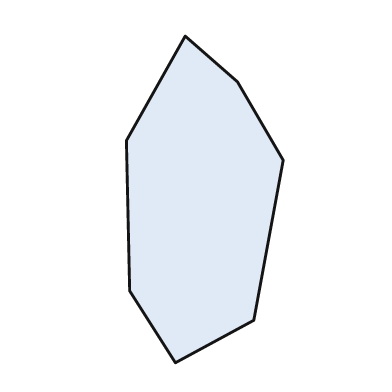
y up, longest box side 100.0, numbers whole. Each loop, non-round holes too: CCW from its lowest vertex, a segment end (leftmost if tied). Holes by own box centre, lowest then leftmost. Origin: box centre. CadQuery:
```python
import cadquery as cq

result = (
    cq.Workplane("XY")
    .moveTo(-9.0, -50.0)
    .lineTo(15.0, -37.0)
    .lineTo(24.0, 12.0)
    .lineTo(10.0, 36.0)
    .lineTo(-6.0, 50.0)
    .lineTo(-24.0, 18.0)
    .lineTo(-23.0, -28.0)
    .close()
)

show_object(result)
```